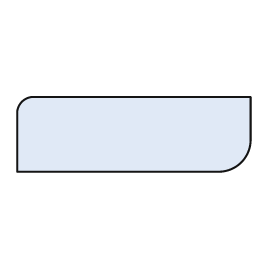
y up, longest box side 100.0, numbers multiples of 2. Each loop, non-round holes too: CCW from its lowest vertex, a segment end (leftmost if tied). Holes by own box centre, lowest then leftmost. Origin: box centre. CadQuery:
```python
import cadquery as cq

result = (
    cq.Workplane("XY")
    .moveTo(-50.0, -16.0)
    .lineTo(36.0, -16.0)
    .threePointArc((46.0, -12.0), (50.0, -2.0))
    .lineTo(50.0, 16.0)
    .lineTo(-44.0, 16.0)
    .threePointArc((-48.0, 14.0), (-50.0, 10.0))
    .close()
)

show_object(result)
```